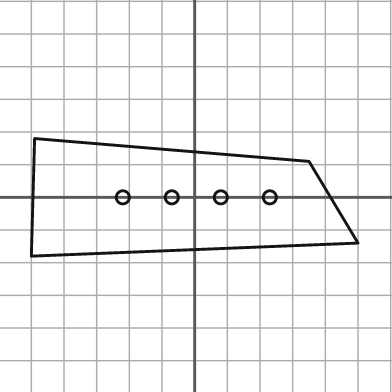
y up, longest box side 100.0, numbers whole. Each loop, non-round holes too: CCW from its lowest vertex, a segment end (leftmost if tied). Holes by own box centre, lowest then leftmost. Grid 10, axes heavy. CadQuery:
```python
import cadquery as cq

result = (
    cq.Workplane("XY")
    .moveTo(-50.0, -18.0)
    .lineTo(50.0, -14.0)
    .lineTo(35.0, 11.0)
    .lineTo(-49.0, 18.0)
    .close()
    .moveTo(-22.0, 0.0)
    .circle(2.0)
    .moveTo(-7.0, 0.0)
    .circle(2.0)
    .moveTo(8.0, 0.0)
    .circle(2.0)
    .moveTo(23.0, 0.0)
    .circle(2.0)
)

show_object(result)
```